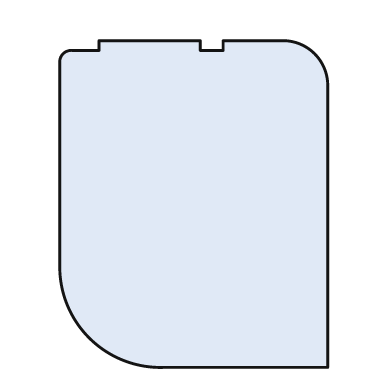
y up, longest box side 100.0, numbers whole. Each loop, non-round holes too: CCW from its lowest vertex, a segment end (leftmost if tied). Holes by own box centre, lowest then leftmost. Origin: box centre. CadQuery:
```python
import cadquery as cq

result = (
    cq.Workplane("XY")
    .moveTo(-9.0, -50.0)
    .lineTo(41.0, -50.0)
    .lineTo(41.0, 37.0)
    .threePointArc((37.0, 46.0), (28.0, 50.0))
    .lineTo(9.0, 50.0)
    .lineTo(9.0, 47.0)
    .lineTo(2.0, 47.0)
    .lineTo(2.0, 50.0)
    .lineTo(-29.0, 50.0)
    .lineTo(-29.0, 47.0)
    .lineTo(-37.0, 47.0)
    .threePointArc((-40.0, 46.0), (-41.0, 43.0))
    .lineTo(-41.0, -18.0)
    .threePointArc((-32.0, -41.0), (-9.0, -50.0))
    .close()
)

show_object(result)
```